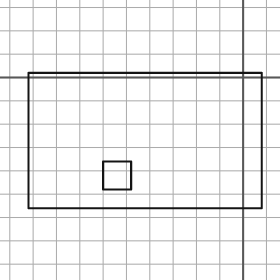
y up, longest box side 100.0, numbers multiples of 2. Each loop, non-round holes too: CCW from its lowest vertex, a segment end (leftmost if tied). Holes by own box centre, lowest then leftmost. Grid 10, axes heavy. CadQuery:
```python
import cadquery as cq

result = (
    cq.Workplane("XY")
    .moveTo(-92.0, -56.0)
    .lineTo(8.0, -56.0)
    .lineTo(8.0, 2.0)
    .lineTo(-92.0, 2.0)
    .close()
    .moveTo(-60.0, -48.0)
    .lineTo(-48.0, -48.0)
    .lineTo(-48.0, -36.0)
    .lineTo(-60.0, -36.0)
    .close()
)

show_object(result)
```